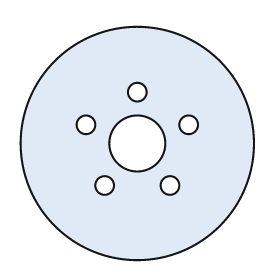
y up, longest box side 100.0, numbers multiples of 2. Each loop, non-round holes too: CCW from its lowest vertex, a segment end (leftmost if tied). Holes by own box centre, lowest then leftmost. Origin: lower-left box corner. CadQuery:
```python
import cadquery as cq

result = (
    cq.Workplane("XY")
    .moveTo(50.0, 50.0)
    .circle(50.0)
    .moveTo(36.0, 32.0)
    .circle(4.0)
    .moveTo(64.0, 32.0)
    .circle(4.0)
    .moveTo(50.0, 50.0)
    .circle(12.0)
    .moveTo(28.0, 58.0)
    .circle(4.0)
    .moveTo(72.0, 58.0)
    .circle(4.0)
    .moveTo(50.0, 72.0)
    .circle(4.0)
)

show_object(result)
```